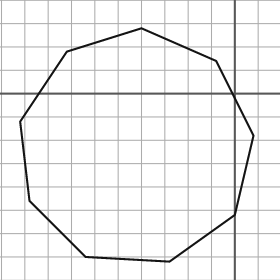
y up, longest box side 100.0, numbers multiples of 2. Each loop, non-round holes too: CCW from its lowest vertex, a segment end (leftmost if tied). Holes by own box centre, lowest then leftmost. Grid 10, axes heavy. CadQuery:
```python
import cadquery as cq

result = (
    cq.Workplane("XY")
    .moveTo(-28.0, -72.0)
    .lineTo(0.0, -52.0)
    .lineTo(8.0, -18.0)
    .lineTo(-8.0, 14.0)
    .lineTo(-40.0, 28.0)
    .lineTo(-72.0, 18.0)
    .lineTo(-92.0, -12.0)
    .lineTo(-88.0, -46.0)
    .lineTo(-64.0, -70.0)
    .close()
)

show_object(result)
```